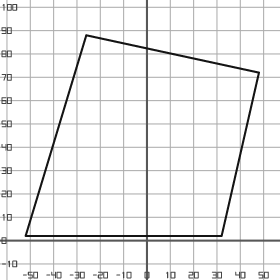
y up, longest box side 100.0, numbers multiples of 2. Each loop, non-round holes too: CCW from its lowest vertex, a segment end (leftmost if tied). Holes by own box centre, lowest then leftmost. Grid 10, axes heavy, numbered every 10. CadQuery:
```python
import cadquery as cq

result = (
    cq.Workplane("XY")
    .moveTo(-52.0, 2.0)
    .lineTo(32.0, 2.0)
    .lineTo(48.0, 72.0)
    .lineTo(-26.0, 88.0)
    .close()
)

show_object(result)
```